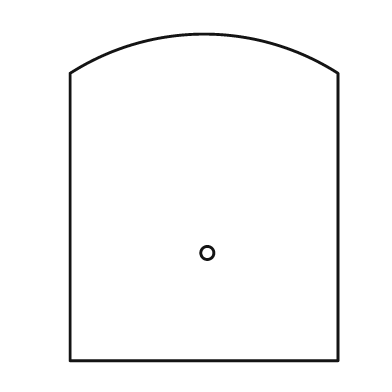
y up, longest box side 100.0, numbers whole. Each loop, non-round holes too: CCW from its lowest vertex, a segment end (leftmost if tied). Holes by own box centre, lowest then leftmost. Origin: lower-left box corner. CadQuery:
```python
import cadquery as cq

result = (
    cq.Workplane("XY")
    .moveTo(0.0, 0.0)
    .lineTo(82.0, 0.0)
    .lineTo(82.0, 88.0)
    .threePointArc((41.0, 100.0), (0.0, 88.0))
    .close()
    .moveTo(42.0, 33.0)
    .circle(2.0)
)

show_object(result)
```